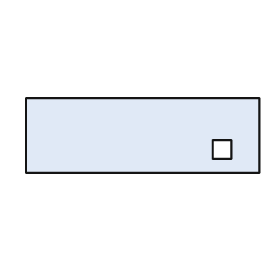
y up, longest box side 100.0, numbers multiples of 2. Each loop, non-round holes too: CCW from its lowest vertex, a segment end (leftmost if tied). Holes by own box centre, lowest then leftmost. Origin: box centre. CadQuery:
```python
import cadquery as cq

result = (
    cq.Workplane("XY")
    .moveTo(-50.0, -16.0)
    .lineTo(50.0, -16.0)
    .lineTo(50.0, 16.0)
    .lineTo(-50.0, 16.0)
    .close()
    .moveTo(30.0, -10.0)
    .lineTo(38.0, -10.0)
    .lineTo(38.0, -2.0)
    .lineTo(30.0, -2.0)
    .close()
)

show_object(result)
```